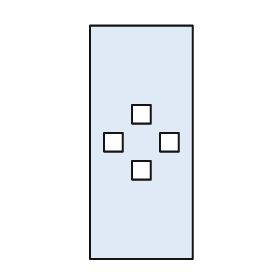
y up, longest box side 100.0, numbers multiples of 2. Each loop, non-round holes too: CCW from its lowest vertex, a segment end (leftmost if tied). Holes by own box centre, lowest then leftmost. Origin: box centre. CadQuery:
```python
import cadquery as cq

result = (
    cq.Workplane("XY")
    .moveTo(-22.0, -50.0)
    .lineTo(22.0, -50.0)
    .lineTo(22.0, 50.0)
    .lineTo(-22.0, 50.0)
    .close()
    .moveTo(-4.0, -16.0)
    .lineTo(4.0, -16.0)
    .lineTo(4.0, -8.0)
    .lineTo(-4.0, -8.0)
    .close()
    .moveTo(-16.0, -4.0)
    .lineTo(-8.0, -4.0)
    .lineTo(-8.0, 4.0)
    .lineTo(-16.0, 4.0)
    .close()
    .moveTo(8.0, -4.0)
    .lineTo(16.0, -4.0)
    .lineTo(16.0, 4.0)
    .lineTo(8.0, 4.0)
    .close()
    .moveTo(-4.0, 8.0)
    .lineTo(4.0, 8.0)
    .lineTo(4.0, 16.0)
    .lineTo(-4.0, 16.0)
    .close()
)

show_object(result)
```